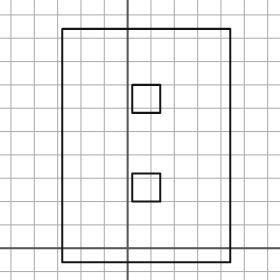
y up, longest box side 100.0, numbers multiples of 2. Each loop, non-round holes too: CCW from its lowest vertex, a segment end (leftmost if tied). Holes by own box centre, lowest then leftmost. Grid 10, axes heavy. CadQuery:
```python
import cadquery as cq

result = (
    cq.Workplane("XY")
    .moveTo(-28.0, -6.0)
    .lineTo(44.0, -6.0)
    .lineTo(44.0, 94.0)
    .lineTo(-28.0, 94.0)
    .close()
    .moveTo(2.0, 20.0)
    .lineTo(14.0, 20.0)
    .lineTo(14.0, 32.0)
    .lineTo(2.0, 32.0)
    .close()
    .moveTo(2.0, 58.0)
    .lineTo(14.0, 58.0)
    .lineTo(14.0, 70.0)
    .lineTo(2.0, 70.0)
    .close()
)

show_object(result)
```